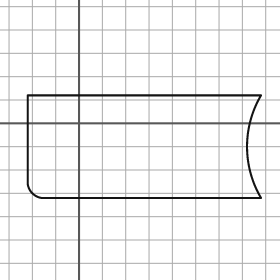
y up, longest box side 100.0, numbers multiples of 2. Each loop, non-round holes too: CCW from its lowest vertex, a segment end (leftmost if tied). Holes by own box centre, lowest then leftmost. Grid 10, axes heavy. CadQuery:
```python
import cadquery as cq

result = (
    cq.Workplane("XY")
    .moveTo(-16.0, -32.0)
    .lineTo(78.0, -32.0)
    .threePointArc((72.0, -10.0), (78.0, 12.0))
    .lineTo(-22.0, 12.0)
    .lineTo(-22.0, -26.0)
    .threePointArc((-20.0, -30.0), (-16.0, -32.0))
    .close()
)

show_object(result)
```